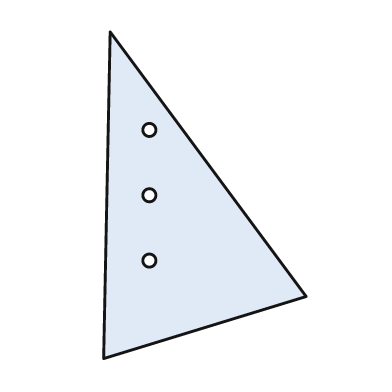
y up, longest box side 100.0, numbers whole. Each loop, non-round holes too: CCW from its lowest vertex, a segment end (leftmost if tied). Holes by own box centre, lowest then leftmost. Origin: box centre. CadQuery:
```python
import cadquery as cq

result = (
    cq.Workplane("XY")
    .moveTo(-31.0, -50.0)
    .lineTo(31.0, -31.0)
    .lineTo(-29.0, 50.0)
    .close()
    .moveTo(-17.0, -20.0)
    .circle(2.0)
    .moveTo(-17.0, 0.0)
    .circle(2.0)
    .moveTo(-17.0, 20.0)
    .circle(2.0)
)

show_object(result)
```